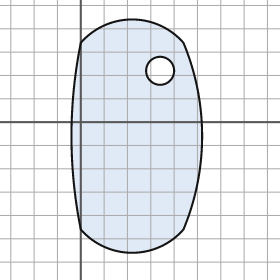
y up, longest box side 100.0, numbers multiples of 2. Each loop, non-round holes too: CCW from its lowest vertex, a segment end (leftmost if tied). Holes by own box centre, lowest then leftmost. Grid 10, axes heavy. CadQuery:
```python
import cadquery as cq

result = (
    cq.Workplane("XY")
    .moveTo(0.0, -46.0)
    .threePointArc((22.0, -56.0), (44.0, -46.0))
    .threePointArc((52.0, -6.0), (44.0, 34.0))
    .threePointArc((22.0, 44.0), (0.0, 34.0))
    .threePointArc((-4.0, -6.0), (0.0, -46.0))
    .close()
    .moveTo(34.0, 22.0)
    .circle(6.0)
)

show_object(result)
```